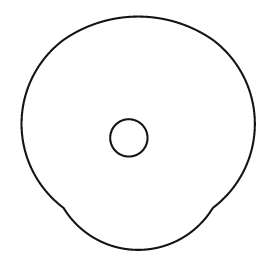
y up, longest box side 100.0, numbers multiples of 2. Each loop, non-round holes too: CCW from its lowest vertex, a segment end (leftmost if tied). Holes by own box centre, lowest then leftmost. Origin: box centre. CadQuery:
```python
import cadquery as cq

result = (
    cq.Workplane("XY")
    .moveTo(-32.0, -32.0)
    .threePointArc((0.0, -50.0), (32.0, -32.0))
    .threePointArc((50.0, 4.0), (32.0, 40.0))
    .threePointArc((0.0, 50.0), (-32.0, 40.0))
    .threePointArc((-50.0, 4.0), (-32.0, -32.0))
    .close()
    .moveTo(-4.0, -2.0)
    .circle(8.0)
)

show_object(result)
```